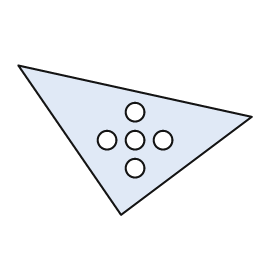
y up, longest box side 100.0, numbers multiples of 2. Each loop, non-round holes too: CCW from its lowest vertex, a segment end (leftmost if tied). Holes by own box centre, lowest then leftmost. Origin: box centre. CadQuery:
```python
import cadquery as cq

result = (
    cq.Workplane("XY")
    .moveTo(-6.0, -32.0)
    .lineTo(50.0, 10.0)
    .lineTo(-50.0, 32.0)
    .close()
    .moveTo(0.0, -12.0)
    .circle(4.0)
    .moveTo(-12.0, 0.0)
    .circle(4.0)
    .moveTo(0.0, 0.0)
    .circle(4.0)
    .moveTo(12.0, 0.0)
    .circle(4.0)
    .moveTo(0.0, 12.0)
    .circle(4.0)
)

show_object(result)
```